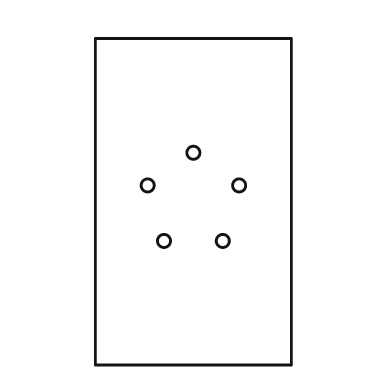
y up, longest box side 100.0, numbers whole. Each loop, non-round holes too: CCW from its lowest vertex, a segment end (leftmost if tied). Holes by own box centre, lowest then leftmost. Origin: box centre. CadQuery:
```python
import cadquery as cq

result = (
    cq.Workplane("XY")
    .moveTo(-30.0, -50.0)
    .lineTo(30.0, -50.0)
    .lineTo(30.0, 50.0)
    .lineTo(-30.0, 50.0)
    .close()
    .moveTo(-9.0, -12.0)
    .circle(2.0)
    .moveTo(9.0, -12.0)
    .circle(2.0)
    .moveTo(-14.0, 5.0)
    .circle(2.0)
    .moveTo(14.0, 5.0)
    .circle(2.0)
    .moveTo(0.0, 15.0)
    .circle(2.0)
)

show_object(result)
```